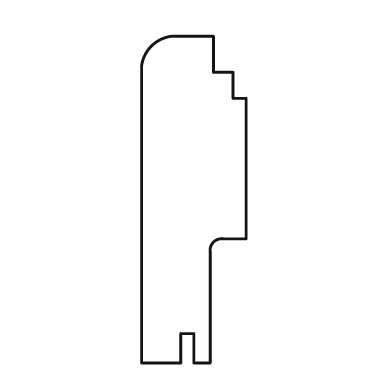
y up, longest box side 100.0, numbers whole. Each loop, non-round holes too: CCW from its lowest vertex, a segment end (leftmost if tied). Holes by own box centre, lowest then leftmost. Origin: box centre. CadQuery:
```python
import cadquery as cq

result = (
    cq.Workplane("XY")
    .moveTo(-16.0, -50.0)
    .lineTo(-4.0, -50.0)
    .lineTo(-4.0, -41.0)
    .lineTo(0.0, -41.0)
    .lineTo(0.0, -50.0)
    .lineTo(5.0, -50.0)
    .lineTo(5.0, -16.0)
    .threePointArc((6.0, -13.0), (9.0, -12.0))
    .lineTo(16.0, -12.0)
    .lineTo(16.0, 31.0)
    .lineTo(12.0, 31.0)
    .lineTo(12.0, 39.0)
    .lineTo(6.0, 39.0)
    .lineTo(6.0, 50.0)
    .lineTo(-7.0, 50.0)
    .threePointArc((-13.0, 47.0), (-16.0, 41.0))
    .close()
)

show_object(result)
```